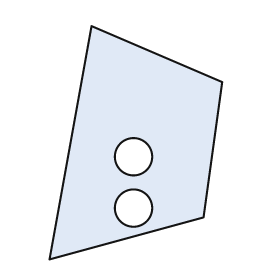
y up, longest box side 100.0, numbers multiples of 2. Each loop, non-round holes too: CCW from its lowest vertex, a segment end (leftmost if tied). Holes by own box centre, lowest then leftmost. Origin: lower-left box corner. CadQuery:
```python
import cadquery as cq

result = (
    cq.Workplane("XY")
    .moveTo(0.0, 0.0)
    .lineTo(66.0, 18.0)
    .lineTo(74.0, 76.0)
    .lineTo(18.0, 100.0)
    .close()
    .moveTo(36.0, 22.0)
    .circle(8.0)
    .moveTo(36.0, 44.0)
    .circle(8.0)
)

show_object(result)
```